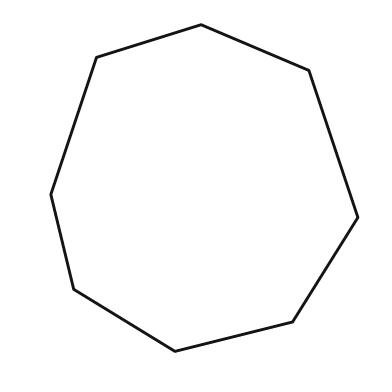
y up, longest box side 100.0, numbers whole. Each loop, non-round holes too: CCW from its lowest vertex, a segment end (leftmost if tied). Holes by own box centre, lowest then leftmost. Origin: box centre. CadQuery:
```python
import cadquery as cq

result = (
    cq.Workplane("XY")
    .moveTo(-9.0, -50.0)
    .lineTo(27.0, -41.0)
    .lineTo(47.0, -9.0)
    .lineTo(32.0, 36.0)
    .lineTo(-1.0, 50.0)
    .lineTo(-33.0, 40.0)
    .lineTo(-47.0, -2.0)
    .lineTo(-40.0, -31.0)
    .close()
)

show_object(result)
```